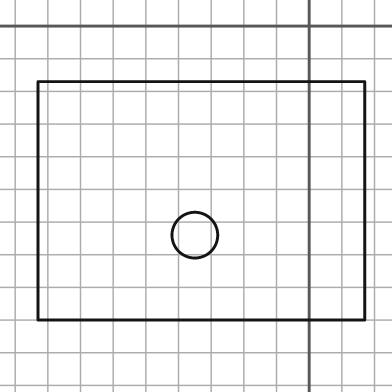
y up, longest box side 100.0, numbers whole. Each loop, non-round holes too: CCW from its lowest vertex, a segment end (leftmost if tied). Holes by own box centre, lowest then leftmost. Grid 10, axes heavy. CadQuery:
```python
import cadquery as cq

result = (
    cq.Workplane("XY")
    .moveTo(-83.0, -90.0)
    .lineTo(17.0, -90.0)
    .lineTo(17.0, -17.0)
    .lineTo(-83.0, -17.0)
    .close()
    .moveTo(-35.0, -64.0)
    .circle(7.0)
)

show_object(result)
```